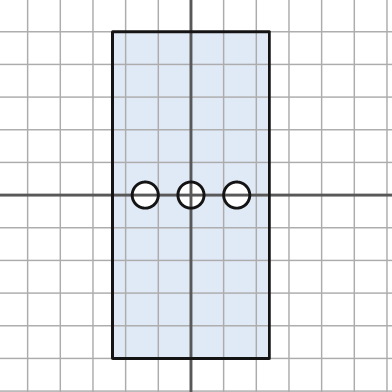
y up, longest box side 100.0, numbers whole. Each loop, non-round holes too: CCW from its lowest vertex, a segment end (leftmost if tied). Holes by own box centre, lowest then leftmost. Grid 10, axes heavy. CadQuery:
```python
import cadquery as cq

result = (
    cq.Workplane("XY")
    .moveTo(-24.0, -50.0)
    .lineTo(24.0, -50.0)
    .lineTo(24.0, 50.0)
    .lineTo(-24.0, 50.0)
    .close()
    .moveTo(-14.0, 0.0)
    .circle(4.0)
    .moveTo(0.0, 0.0)
    .circle(4.0)
    .moveTo(14.0, 0.0)
    .circle(4.0)
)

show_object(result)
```